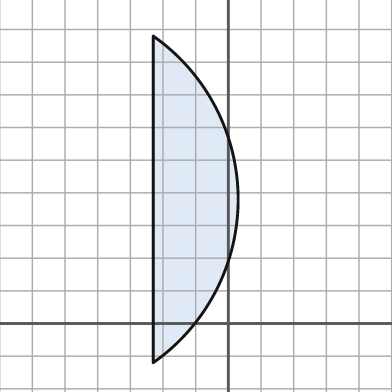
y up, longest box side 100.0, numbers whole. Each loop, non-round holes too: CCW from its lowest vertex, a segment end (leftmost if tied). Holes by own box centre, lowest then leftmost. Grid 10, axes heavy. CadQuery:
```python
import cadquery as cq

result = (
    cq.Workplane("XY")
    .moveTo(-23.0, -12.0)
    .threePointArc((3.0, 38.0), (-23.0, 88.0))
    .close()
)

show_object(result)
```